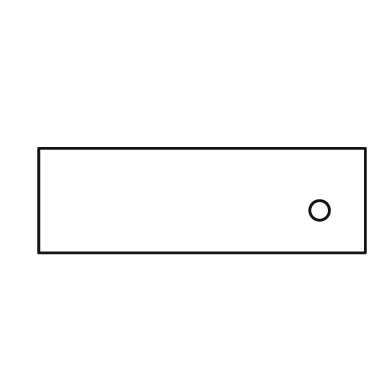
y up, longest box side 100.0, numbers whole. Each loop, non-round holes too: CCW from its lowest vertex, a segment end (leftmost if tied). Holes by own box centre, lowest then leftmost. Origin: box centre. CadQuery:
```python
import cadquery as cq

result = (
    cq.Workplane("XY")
    .moveTo(-50.0, -16.0)
    .lineTo(50.0, -16.0)
    .lineTo(50.0, 16.0)
    .lineTo(-50.0, 16.0)
    .close()
    .moveTo(36.0, -3.0)
    .circle(3.0)
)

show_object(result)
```